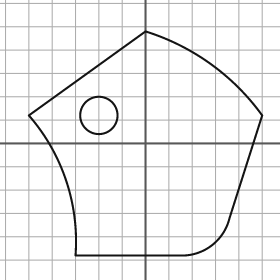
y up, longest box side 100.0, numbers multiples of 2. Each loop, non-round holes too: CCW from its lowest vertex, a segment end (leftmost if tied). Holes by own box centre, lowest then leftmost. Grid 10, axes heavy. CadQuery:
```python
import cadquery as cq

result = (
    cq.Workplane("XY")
    .moveTo(-30.0, -48.0)
    .lineTo(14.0, -48.0)
    .threePointArc((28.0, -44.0), (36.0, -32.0))
    .lineTo(50.0, 12.0)
    .threePointArc((28.0, 34.0), (0.0, 48.0))
    .lineTo(-50.0, 12.0)
    .threePointArc((-34.0, -16.0), (-30.0, -48.0))
    .close()
    .moveTo(-20.0, 12.0)
    .circle(8.0)
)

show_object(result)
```